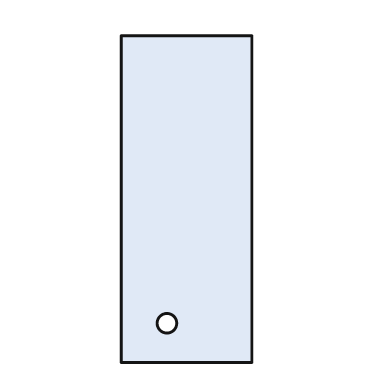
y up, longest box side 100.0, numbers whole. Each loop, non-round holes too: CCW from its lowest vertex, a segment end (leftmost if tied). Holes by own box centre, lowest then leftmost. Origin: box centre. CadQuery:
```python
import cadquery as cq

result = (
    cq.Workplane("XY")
    .moveTo(-20.0, -50.0)
    .lineTo(20.0, -50.0)
    .lineTo(20.0, 50.0)
    .lineTo(-20.0, 50.0)
    .close()
    .moveTo(-6.0, -38.0)
    .circle(3.0)
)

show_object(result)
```